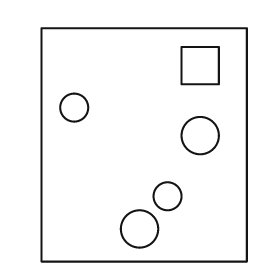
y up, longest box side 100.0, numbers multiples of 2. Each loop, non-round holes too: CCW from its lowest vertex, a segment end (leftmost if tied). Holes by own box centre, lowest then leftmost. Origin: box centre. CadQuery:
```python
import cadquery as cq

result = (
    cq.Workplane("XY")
    .moveTo(-44.0, -50.0)
    .lineTo(44.0, -50.0)
    .lineTo(44.0, 50.0)
    .lineTo(-44.0, 50.0)
    .close()
    .moveTo(-2.0, -36.0)
    .circle(8.0)
    .moveTo(10.0, -22.0)
    .circle(6.0)
    .moveTo(24.0, 4.0)
    .circle(8.0)
    .moveTo(-30.0, 16.0)
    .circle(6.0)
    .moveTo(16.0, 26.0)
    .lineTo(32.0, 26.0)
    .lineTo(32.0, 42.0)
    .lineTo(16.0, 42.0)
    .close()
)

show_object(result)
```